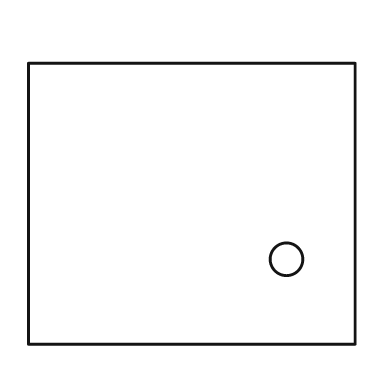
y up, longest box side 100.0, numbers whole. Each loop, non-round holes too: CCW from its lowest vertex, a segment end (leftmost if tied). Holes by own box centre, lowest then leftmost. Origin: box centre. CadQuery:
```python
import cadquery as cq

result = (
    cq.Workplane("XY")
    .moveTo(-50.0, -43.0)
    .lineTo(50.0, -43.0)
    .lineTo(50.0, 43.0)
    .lineTo(-50.0, 43.0)
    .close()
    .moveTo(29.0, -17.0)
    .circle(5.0)
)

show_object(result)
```